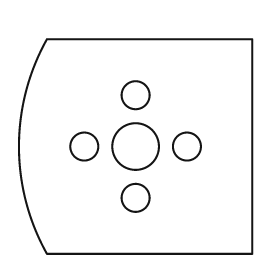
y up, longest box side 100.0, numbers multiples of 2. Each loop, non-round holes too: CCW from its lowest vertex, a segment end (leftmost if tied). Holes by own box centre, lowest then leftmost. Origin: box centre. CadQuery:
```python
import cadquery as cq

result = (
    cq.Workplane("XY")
    .moveTo(-38.0, -46.0)
    .lineTo(50.0, -46.0)
    .lineTo(50.0, 46.0)
    .lineTo(-38.0, 46.0)
    .threePointArc((-50.0, 0.0), (-38.0, -46.0))
    .close()
    .moveTo(0.0, -22.0)
    .circle(6.0)
    .moveTo(-22.0, 0.0)
    .circle(6.0)
    .moveTo(0.0, 0.0)
    .circle(10.0)
    .moveTo(22.0, 0.0)
    .circle(6.0)
    .moveTo(0.0, 22.0)
    .circle(6.0)
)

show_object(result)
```